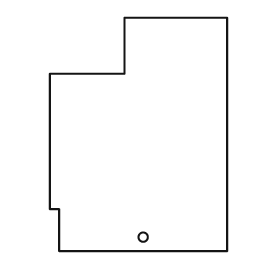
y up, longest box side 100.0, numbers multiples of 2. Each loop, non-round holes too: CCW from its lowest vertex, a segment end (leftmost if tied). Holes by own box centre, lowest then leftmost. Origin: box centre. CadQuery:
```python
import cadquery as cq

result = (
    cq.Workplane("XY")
    .moveTo(-34.0, -50.0)
    .lineTo(38.0, -50.0)
    .lineTo(38.0, 50.0)
    .lineTo(-6.0, 50.0)
    .lineTo(-6.0, 26.0)
    .lineTo(-38.0, 26.0)
    .lineTo(-38.0, -32.0)
    .lineTo(-34.0, -32.0)
    .close()
    .moveTo(2.0, -44.0)
    .circle(2.0)
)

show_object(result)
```